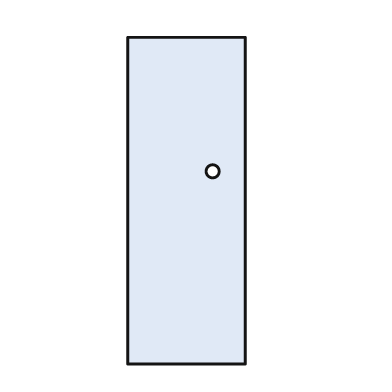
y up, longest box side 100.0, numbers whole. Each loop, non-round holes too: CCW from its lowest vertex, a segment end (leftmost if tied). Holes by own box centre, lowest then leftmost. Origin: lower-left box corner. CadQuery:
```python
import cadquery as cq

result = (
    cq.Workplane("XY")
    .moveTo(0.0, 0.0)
    .lineTo(36.0, 0.0)
    .lineTo(36.0, 100.0)
    .lineTo(0.0, 100.0)
    .close()
    .moveTo(26.0, 59.0)
    .circle(2.0)
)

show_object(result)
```